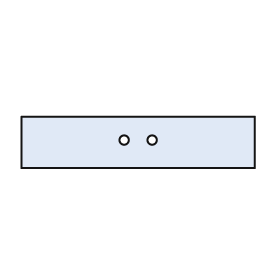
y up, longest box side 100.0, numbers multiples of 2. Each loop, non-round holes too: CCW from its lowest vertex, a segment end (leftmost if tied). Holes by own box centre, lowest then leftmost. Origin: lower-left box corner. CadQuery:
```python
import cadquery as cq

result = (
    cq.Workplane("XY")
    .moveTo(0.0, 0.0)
    .lineTo(100.0, 0.0)
    .lineTo(100.0, 22.0)
    .lineTo(0.0, 22.0)
    .close()
    .moveTo(44.0, 12.0)
    .circle(2.0)
    .moveTo(56.0, 12.0)
    .circle(2.0)
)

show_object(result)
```